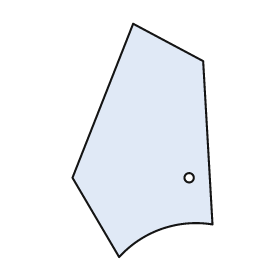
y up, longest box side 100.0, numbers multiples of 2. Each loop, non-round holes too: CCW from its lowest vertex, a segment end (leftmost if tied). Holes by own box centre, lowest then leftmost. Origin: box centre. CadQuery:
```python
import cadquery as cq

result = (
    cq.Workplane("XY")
    .moveTo(-10.0, -50.0)
    .threePointArc((8.0, -38.0), (30.0, -36.0))
    .lineTo(26.0, 34.0)
    .lineTo(-4.0, 50.0)
    .lineTo(-30.0, -16.0)
    .close()
    .moveTo(20.0, -16.0)
    .circle(2.0)
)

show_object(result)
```